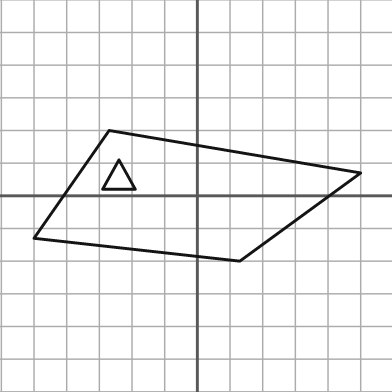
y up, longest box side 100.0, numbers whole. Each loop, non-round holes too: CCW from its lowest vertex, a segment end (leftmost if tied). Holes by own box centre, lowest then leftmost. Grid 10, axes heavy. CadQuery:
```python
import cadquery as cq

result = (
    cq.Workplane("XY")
    .moveTo(13.0, -20.0)
    .lineTo(50.0, 7.0)
    .lineTo(-27.0, 20.0)
    .lineTo(-50.0, -13.0)
    .close()
    .moveTo(-29.0, 2.0)
    .lineTo(-19.0, 2.0)
    .lineTo(-24.0, 11.0)
    .close()
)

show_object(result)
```